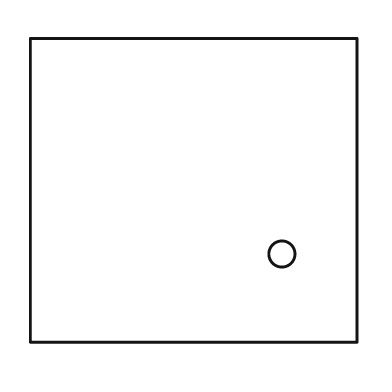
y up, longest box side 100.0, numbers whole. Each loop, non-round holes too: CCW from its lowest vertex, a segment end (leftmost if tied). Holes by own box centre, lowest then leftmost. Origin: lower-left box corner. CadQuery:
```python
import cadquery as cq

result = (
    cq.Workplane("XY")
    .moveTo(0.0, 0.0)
    .lineTo(100.0, 0.0)
    .lineTo(100.0, 93.0)
    .lineTo(0.0, 93.0)
    .close()
    .moveTo(77.0, 27.0)
    .circle(4.0)
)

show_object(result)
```